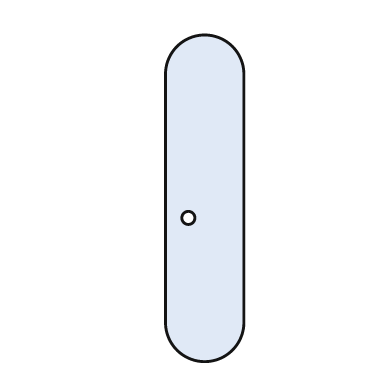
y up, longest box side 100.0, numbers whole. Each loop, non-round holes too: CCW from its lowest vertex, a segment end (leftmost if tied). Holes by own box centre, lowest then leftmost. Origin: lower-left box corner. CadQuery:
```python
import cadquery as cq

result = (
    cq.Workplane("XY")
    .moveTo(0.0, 12.0)
    .threePointArc((12.0, 0.0), (24.0, 12.0))
    .lineTo(24.0, 88.0)
    .threePointArc((12.0, 100.0), (0.0, 88.0))
    .close()
    .moveTo(7.0, 44.0)
    .circle(2.0)
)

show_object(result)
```